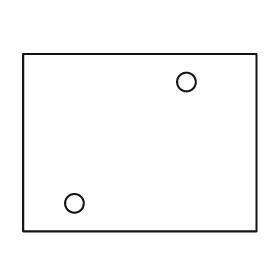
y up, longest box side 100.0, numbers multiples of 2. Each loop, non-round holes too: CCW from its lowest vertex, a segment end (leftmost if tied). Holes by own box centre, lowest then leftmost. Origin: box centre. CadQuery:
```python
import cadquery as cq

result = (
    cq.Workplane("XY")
    .moveTo(-50.0, -38.0)
    .lineTo(50.0, -38.0)
    .lineTo(50.0, 38.0)
    .lineTo(-50.0, 38.0)
    .close()
    .moveTo(-28.0, -26.0)
    .circle(4.0)
    .moveTo(20.0, 26.0)
    .circle(4.0)
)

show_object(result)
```